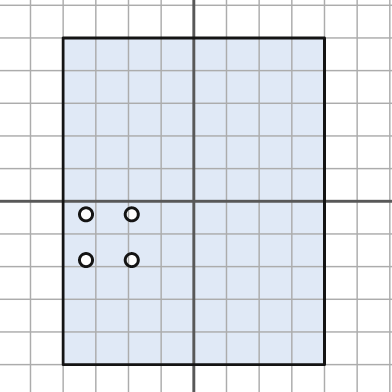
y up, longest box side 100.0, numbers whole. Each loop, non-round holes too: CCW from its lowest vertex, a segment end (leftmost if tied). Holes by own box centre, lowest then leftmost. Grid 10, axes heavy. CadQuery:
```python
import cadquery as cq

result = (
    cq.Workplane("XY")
    .moveTo(-40.0, -50.0)
    .lineTo(40.0, -50.0)
    .lineTo(40.0, 50.0)
    .lineTo(-40.0, 50.0)
    .close()
    .moveTo(-33.0, -18.0)
    .circle(2.0)
    .moveTo(-19.0, -18.0)
    .circle(2.0)
    .moveTo(-33.0, -4.0)
    .circle(2.0)
    .moveTo(-19.0, -4.0)
    .circle(2.0)
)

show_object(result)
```